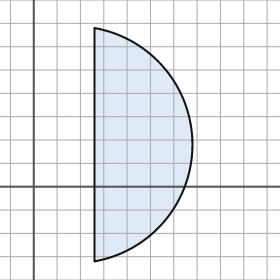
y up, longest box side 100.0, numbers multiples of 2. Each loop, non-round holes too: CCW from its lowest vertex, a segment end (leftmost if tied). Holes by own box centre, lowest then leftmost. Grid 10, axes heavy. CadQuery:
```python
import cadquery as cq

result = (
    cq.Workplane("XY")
    .moveTo(26.0, -32.0)
    .threePointArc((68.0, 18.0), (26.0, 68.0))
    .close()
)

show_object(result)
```